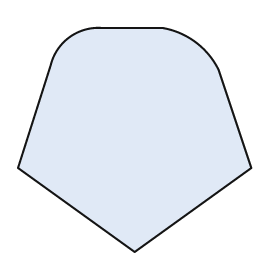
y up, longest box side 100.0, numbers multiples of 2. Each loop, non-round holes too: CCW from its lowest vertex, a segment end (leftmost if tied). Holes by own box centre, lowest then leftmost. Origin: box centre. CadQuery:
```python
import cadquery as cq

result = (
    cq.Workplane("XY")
    .moveTo(0.0, -48.0)
    .lineTo(50.0, -12.0)
    .lineTo(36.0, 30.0)
    .threePointArc((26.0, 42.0), (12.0, 48.0))
    .lineTo(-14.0, 48.0)
    .threePointArc((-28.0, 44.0), (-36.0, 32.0))
    .lineTo(-50.0, -12.0)
    .close()
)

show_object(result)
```